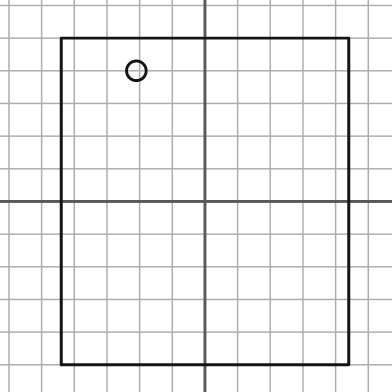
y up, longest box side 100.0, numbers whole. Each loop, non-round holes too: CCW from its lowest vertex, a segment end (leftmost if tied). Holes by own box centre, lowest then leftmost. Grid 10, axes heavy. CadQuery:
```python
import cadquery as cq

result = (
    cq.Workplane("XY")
    .moveTo(-44.0, -50.0)
    .lineTo(44.0, -50.0)
    .lineTo(44.0, 50.0)
    .lineTo(-44.0, 50.0)
    .close()
    .moveTo(-21.0, 40.0)
    .circle(3.0)
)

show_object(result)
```